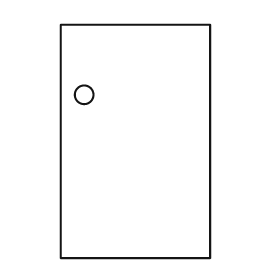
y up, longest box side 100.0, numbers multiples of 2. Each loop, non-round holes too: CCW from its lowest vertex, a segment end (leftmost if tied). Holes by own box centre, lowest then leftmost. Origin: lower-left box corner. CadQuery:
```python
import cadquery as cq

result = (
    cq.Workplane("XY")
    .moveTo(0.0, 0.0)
    .lineTo(64.0, 0.0)
    .lineTo(64.0, 100.0)
    .lineTo(0.0, 100.0)
    .close()
    .moveTo(10.0, 70.0)
    .circle(4.0)
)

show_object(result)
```